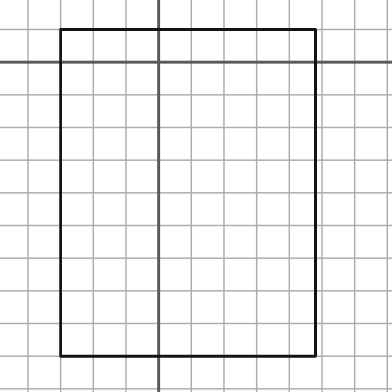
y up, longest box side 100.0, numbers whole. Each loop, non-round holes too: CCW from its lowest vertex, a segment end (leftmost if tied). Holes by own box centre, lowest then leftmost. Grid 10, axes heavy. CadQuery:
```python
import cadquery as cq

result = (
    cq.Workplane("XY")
    .moveTo(-30.0, -90.0)
    .lineTo(48.0, -90.0)
    .lineTo(48.0, 10.0)
    .lineTo(-30.0, 10.0)
    .close()
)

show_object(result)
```